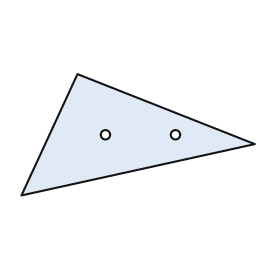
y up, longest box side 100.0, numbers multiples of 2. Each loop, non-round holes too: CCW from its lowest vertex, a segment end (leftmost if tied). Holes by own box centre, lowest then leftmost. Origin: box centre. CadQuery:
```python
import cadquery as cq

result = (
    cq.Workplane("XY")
    .moveTo(-50.0, -26.0)
    .lineTo(50.0, -4.0)
    .lineTo(-26.0, 26.0)
    .close()
    .moveTo(-14.0, 0.0)
    .circle(2.0)
    .moveTo(16.0, 0.0)
    .circle(2.0)
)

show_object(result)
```